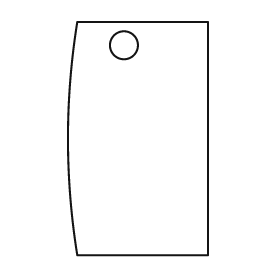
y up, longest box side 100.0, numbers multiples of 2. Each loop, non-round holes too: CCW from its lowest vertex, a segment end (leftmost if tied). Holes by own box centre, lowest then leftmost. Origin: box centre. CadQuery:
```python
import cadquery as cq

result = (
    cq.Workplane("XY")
    .moveTo(-26.0, -50.0)
    .lineTo(30.0, -50.0)
    .lineTo(30.0, 50.0)
    .lineTo(-26.0, 50.0)
    .threePointArc((-30.0, 0.0), (-26.0, -50.0))
    .close()
    .moveTo(-6.0, 40.0)
    .circle(6.0)
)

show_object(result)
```